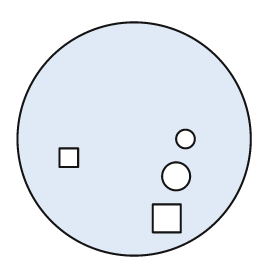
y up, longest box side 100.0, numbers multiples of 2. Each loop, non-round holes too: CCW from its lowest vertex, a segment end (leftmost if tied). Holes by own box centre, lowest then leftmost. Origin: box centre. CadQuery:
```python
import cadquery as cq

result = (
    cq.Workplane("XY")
    .moveTo(0.0, 0.0)
    .circle(50.0)
    .moveTo(8.0, -40.0)
    .lineTo(20.0, -40.0)
    .lineTo(20.0, -28.0)
    .lineTo(8.0, -28.0)
    .close()
    .moveTo(18.0, -16.0)
    .circle(6.0)
    .moveTo(-32.0, -12.0)
    .lineTo(-24.0, -12.0)
    .lineTo(-24.0, -4.0)
    .lineTo(-32.0, -4.0)
    .close()
    .moveTo(22.0, 0.0)
    .circle(4.0)
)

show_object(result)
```